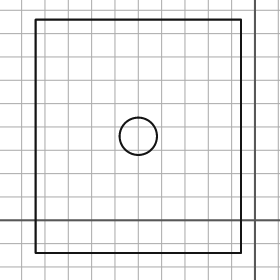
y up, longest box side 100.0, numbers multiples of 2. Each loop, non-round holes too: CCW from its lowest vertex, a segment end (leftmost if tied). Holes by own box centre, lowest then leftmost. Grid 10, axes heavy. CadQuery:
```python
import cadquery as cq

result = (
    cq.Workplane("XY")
    .moveTo(-94.0, -14.0)
    .lineTo(-6.0, -14.0)
    .lineTo(-6.0, 86.0)
    .lineTo(-94.0, 86.0)
    .close()
    .moveTo(-50.0, 36.0)
    .circle(8.0)
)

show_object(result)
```